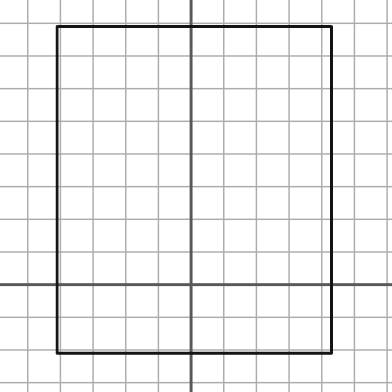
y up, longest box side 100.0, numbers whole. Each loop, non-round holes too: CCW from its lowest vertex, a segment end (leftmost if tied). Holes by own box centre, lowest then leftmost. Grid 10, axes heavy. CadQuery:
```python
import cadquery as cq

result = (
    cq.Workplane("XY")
    .moveTo(-41.0, -21.0)
    .lineTo(43.0, -21.0)
    .lineTo(43.0, 79.0)
    .lineTo(-41.0, 79.0)
    .close()
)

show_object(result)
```